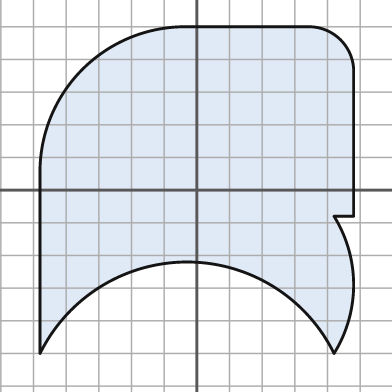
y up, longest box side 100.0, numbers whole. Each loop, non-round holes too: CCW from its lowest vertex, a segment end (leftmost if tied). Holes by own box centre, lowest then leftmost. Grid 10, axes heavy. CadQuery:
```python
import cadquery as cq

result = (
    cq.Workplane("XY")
    .moveTo(-48.0, -50.0)
    .threePointArc((-3.0, -22.0), (42.0, -50.0))
    .threePointArc((48.0, -29.0), (42.0, -8.0))
    .lineTo(48.0, -8.0)
    .lineTo(48.0, 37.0)
    .threePointArc((44.0, 46.0), (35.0, 50.0))
    .lineTo(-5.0, 50.0)
    .threePointArc((-35.0, 37.0), (-48.0, 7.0))
    .close()
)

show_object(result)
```